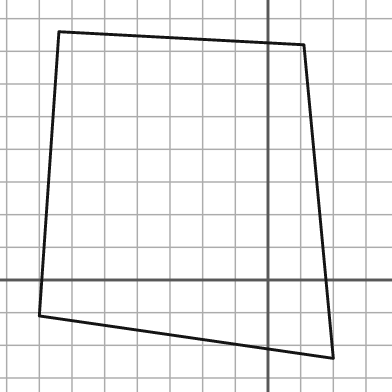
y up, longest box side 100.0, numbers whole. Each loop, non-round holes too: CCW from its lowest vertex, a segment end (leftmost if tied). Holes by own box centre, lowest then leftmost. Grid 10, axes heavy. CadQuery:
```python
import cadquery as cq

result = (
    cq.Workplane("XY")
    .moveTo(20.0, -24.0)
    .lineTo(11.0, 72.0)
    .lineTo(-64.0, 76.0)
    .lineTo(-70.0, -11.0)
    .close()
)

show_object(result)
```